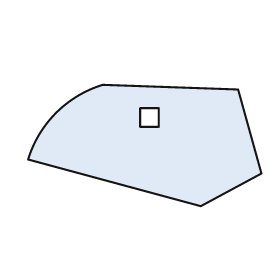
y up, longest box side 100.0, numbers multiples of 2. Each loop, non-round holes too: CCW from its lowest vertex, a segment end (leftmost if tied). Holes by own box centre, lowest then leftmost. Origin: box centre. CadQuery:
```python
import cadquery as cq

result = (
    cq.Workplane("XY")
    .moveTo(24.0, -26.0)
    .lineTo(50.0, -12.0)
    .lineTo(40.0, 24.0)
    .lineTo(-18.0, 26.0)
    .threePointArc((-38.0, 14.0), (-50.0, -6.0))
    .close()
    .moveTo(-2.0, 8.0)
    .lineTo(6.0, 8.0)
    .lineTo(6.0, 16.0)
    .lineTo(-2.0, 16.0)
    .close()
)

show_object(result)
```